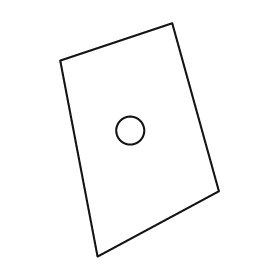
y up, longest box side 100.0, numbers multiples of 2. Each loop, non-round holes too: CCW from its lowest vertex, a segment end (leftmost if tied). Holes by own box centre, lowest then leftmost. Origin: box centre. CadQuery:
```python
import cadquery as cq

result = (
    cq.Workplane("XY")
    .moveTo(-18.0, -50.0)
    .lineTo(34.0, -22.0)
    .lineTo(14.0, 50.0)
    .lineTo(-34.0, 34.0)
    .close()
    .moveTo(-4.0, 4.0)
    .circle(6.0)
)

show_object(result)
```